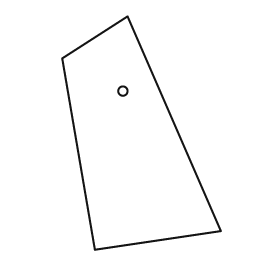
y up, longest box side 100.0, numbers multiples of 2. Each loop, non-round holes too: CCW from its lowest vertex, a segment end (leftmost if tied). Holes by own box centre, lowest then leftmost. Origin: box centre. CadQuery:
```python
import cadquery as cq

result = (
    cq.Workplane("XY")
    .moveTo(-20.0, -50.0)
    .lineTo(34.0, -42.0)
    .lineTo(-6.0, 50.0)
    .lineTo(-34.0, 32.0)
    .close()
    .moveTo(-8.0, 18.0)
    .circle(2.0)
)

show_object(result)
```